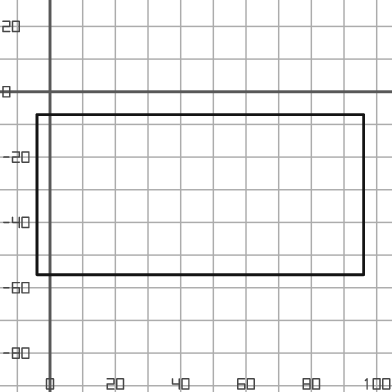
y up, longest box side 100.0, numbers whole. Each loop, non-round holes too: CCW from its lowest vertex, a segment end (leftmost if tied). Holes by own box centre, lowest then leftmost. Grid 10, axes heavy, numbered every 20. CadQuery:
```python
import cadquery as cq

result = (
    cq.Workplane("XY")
    .moveTo(-4.0, -56.0)
    .lineTo(96.0, -56.0)
    .lineTo(96.0, -7.0)
    .lineTo(-4.0, -7.0)
    .close()
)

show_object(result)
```